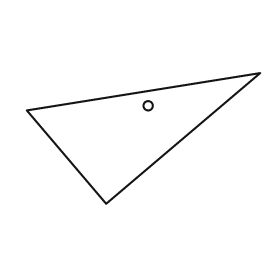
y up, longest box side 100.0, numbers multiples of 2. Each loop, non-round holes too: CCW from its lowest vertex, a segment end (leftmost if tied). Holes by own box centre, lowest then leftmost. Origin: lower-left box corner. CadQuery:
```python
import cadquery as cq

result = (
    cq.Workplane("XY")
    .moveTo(34.0, 0.0)
    .lineTo(100.0, 56.0)
    .lineTo(0.0, 40.0)
    .close()
    .moveTo(52.0, 42.0)
    .circle(2.0)
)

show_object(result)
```